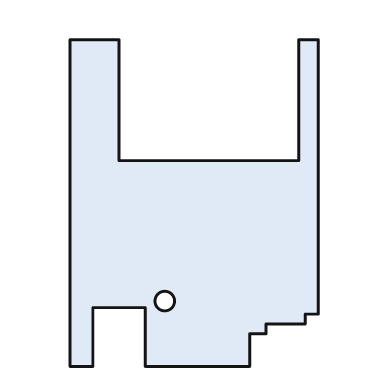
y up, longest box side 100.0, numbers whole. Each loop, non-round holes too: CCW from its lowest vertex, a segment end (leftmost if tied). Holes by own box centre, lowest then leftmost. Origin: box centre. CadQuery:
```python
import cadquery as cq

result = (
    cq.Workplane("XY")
    .moveTo(-38.0, -50.0)
    .lineTo(-31.0, -50.0)
    .lineTo(-31.0, -32.0)
    .lineTo(-15.0, -32.0)
    .lineTo(-15.0, -50.0)
    .lineTo(17.0, -50.0)
    .lineTo(17.0, -40.0)
    .lineTo(22.0, -40.0)
    .lineTo(22.0, -37.0)
    .lineTo(34.0, -37.0)
    .lineTo(34.0, -34.0)
    .lineTo(38.0, -34.0)
    .lineTo(38.0, 50.0)
    .lineTo(32.0, 50.0)
    .lineTo(32.0, 13.0)
    .lineTo(-23.0, 13.0)
    .lineTo(-23.0, 50.0)
    .lineTo(-38.0, 50.0)
    .close()
    .moveTo(-9.0, -30.0)
    .circle(3.0)
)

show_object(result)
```